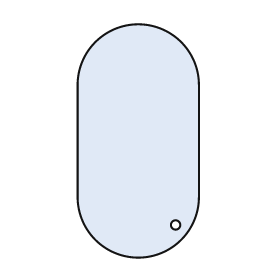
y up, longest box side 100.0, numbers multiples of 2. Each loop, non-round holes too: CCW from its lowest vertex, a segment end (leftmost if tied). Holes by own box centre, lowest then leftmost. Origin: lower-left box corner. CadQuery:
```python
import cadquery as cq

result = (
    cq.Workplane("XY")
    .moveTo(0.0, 26.0)
    .threePointArc((26.0, 0.0), (52.0, 26.0))
    .lineTo(52.0, 74.0)
    .threePointArc((26.0, 100.0), (0.0, 74.0))
    .close()
    .moveTo(42.0, 14.0)
    .circle(2.0)
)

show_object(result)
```